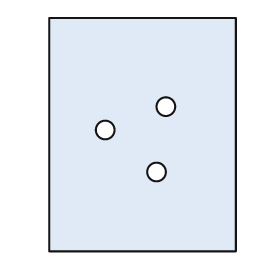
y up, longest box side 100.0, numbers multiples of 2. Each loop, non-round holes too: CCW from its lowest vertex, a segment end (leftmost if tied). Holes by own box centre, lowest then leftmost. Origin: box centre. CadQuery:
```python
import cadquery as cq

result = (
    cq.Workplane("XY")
    .moveTo(-40.0, -50.0)
    .lineTo(40.0, -50.0)
    .lineTo(40.0, 50.0)
    .lineTo(-40.0, 50.0)
    .close()
    .moveTo(6.0, -16.0)
    .circle(4.0)
    .moveTo(-16.0, 2.0)
    .circle(4.0)
    .moveTo(10.0, 12.0)
    .circle(4.0)
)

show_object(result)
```